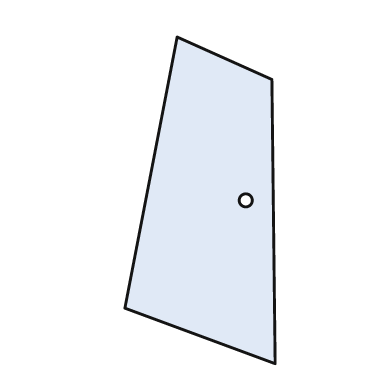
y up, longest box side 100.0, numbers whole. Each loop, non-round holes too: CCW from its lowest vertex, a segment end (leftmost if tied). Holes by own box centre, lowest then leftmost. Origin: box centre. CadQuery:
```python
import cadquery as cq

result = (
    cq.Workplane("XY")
    .moveTo(23.0, -50.0)
    .lineTo(22.0, 37.0)
    .lineTo(-7.0, 50.0)
    .lineTo(-23.0, -33.0)
    .close()
    .moveTo(14.0, 0.0)
    .circle(2.0)
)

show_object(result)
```